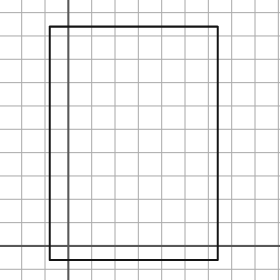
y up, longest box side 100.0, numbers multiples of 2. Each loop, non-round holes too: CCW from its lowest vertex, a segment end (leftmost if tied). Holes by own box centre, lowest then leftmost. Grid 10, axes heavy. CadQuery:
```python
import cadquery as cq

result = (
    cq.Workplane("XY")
    .moveTo(-8.0, -6.0)
    .lineTo(64.0, -6.0)
    .lineTo(64.0, 94.0)
    .lineTo(-8.0, 94.0)
    .close()
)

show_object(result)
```